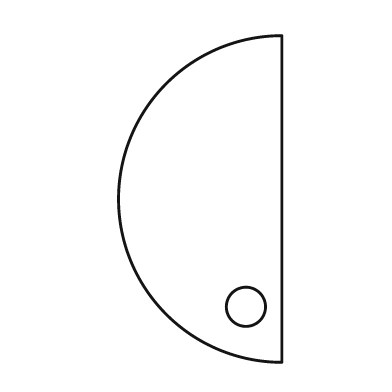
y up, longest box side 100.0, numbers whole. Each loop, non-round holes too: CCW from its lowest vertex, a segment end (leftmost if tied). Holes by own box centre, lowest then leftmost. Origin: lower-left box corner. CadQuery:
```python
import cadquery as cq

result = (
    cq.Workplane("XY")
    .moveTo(50.0, 0.0)
    .lineTo(50.0, 100.0)
    .threePointArc((0.0, 50.0), (50.0, 0.0))
    .close()
    .moveTo(39.0, 17.0)
    .circle(6.0)
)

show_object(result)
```